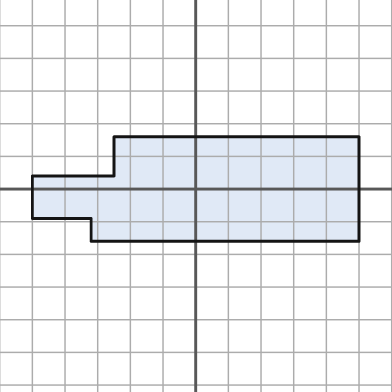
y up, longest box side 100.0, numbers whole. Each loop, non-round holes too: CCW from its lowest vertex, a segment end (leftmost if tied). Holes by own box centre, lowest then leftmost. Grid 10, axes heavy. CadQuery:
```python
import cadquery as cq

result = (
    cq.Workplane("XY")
    .moveTo(-32.0, -16.0)
    .lineTo(50.0, -16.0)
    .lineTo(50.0, 16.0)
    .lineTo(-25.0, 16.0)
    .lineTo(-25.0, 4.0)
    .lineTo(-50.0, 4.0)
    .lineTo(-50.0, -9.0)
    .lineTo(-32.0, -9.0)
    .close()
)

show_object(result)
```